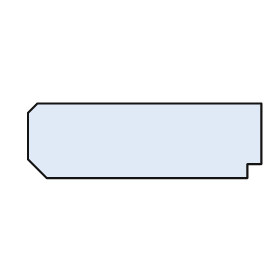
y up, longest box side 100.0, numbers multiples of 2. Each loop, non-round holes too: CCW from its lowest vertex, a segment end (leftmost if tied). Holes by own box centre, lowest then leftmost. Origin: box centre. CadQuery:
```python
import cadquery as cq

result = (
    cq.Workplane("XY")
    .moveTo(-42.0, -16.0)
    .lineTo(44.0, -16.0)
    .lineTo(44.0, -10.0)
    .lineTo(50.0, -10.0)
    .lineTo(50.0, 16.0)
    .lineTo(-46.0, 16.0)
    .lineTo(-50.0, 12.0)
    .lineTo(-50.0, -8.0)
    .close()
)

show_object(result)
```